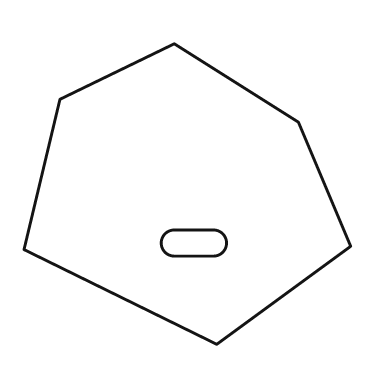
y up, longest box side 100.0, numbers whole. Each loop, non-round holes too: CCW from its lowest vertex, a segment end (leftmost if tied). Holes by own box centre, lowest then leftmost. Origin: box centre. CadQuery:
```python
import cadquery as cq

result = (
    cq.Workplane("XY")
    .moveTo(9.0, -46.0)
    .lineTo(50.0, -16.0)
    .lineTo(34.0, 22.0)
    .lineTo(-4.0, 46.0)
    .lineTo(-39.0, 29.0)
    .lineTo(-50.0, -17.0)
    .close()
    .moveTo(-4.0, -19.0)
    .lineTo(8.0, -19.0)
    .threePointArc((12.0, -15.0), (8.0, -11.0))
    .lineTo(-4.0, -11.0)
    .threePointArc((-8.0, -15.0), (-4.0, -19.0))
    .close()
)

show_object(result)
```